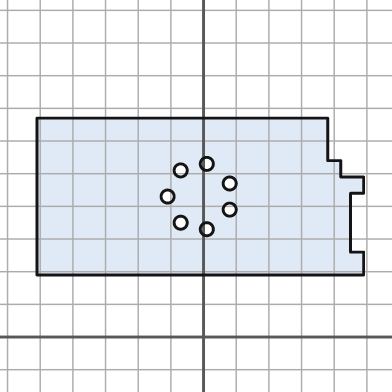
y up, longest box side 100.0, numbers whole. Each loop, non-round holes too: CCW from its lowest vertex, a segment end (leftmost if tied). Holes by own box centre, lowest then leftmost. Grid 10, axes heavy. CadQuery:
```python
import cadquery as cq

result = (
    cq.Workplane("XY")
    .moveTo(-51.0, 19.0)
    .lineTo(49.0, 19.0)
    .lineTo(49.0, 26.0)
    .lineTo(45.0, 26.0)
    .lineTo(45.0, 44.0)
    .lineTo(49.0, 44.0)
    .lineTo(49.0, 49.0)
    .lineTo(42.0, 49.0)
    .lineTo(42.0, 54.0)
    .lineTo(38.0, 54.0)
    .lineTo(38.0, 67.0)
    .lineTo(-51.0, 67.0)
    .close()
    .moveTo(1.0, 33.0)
    .circle(2.0)
    .moveTo(-7.0, 35.0)
    .circle(2.0)
    .moveTo(8.0, 39.0)
    .circle(2.0)
    .moveTo(-11.0, 43.0)
    .circle(2.0)
    .moveTo(8.0, 47.0)
    .circle(2.0)
    .moveTo(-7.0, 51.0)
    .circle(2.0)
    .moveTo(1.0, 53.0)
    .circle(2.0)
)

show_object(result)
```